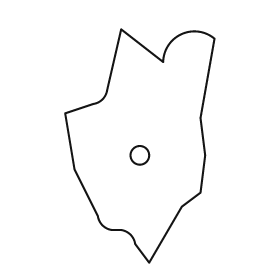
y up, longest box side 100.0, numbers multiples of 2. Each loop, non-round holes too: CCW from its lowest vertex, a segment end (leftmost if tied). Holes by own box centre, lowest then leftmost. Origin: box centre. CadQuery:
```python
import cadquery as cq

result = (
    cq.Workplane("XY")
    .moveTo(4.0, -50.0)
    .lineTo(18.0, -26.0)
    .lineTo(26.0, -20.0)
    .lineTo(28.0, -4.0)
    .lineTo(26.0, 12.0)
    .lineTo(32.0, 46.0)
    .threePointArc((18.0, 48.0), (10.0, 36.0))
    .lineTo(-8.0, 50.0)
    .lineTo(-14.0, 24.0)
    .threePointArc((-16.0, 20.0), (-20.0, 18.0))
    .lineTo(-32.0, 14.0)
    .lineTo(-28.0, -10.0)
    .lineTo(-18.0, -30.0)
    .threePointArc((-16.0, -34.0), (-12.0, -36.0))
    .lineTo(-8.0, -36.0)
    .threePointArc((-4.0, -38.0), (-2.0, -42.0))
    .close()
    .moveTo(0.0, -4.0)
    .circle(4.0)
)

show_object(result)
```